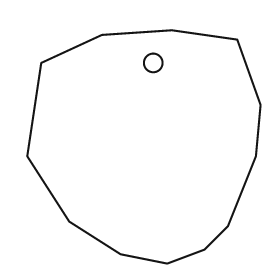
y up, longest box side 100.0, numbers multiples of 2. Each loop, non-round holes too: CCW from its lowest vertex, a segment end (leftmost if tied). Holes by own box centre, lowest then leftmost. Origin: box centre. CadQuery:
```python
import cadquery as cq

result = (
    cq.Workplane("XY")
    .moveTo(10.0, -50.0)
    .lineTo(26.0, -44.0)
    .lineTo(36.0, -34.0)
    .lineTo(48.0, -4.0)
    .lineTo(50.0, 18.0)
    .lineTo(40.0, 46.0)
    .lineTo(12.0, 50.0)
    .lineTo(-18.0, 48.0)
    .lineTo(-44.0, 36.0)
    .lineTo(-50.0, -4.0)
    .lineTo(-32.0, -32.0)
    .lineTo(-10.0, -46.0)
    .close()
    .moveTo(4.0, 36.0)
    .circle(4.0)
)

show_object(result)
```